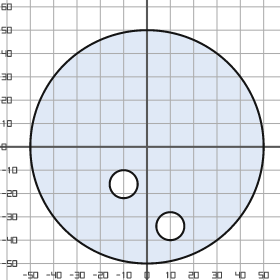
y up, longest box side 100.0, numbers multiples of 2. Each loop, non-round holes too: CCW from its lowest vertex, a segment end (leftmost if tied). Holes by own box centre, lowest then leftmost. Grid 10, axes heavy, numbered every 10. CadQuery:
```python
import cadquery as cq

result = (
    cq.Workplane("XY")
    .moveTo(0.0, 0.0)
    .circle(50.0)
    .moveTo(10.0, -34.0)
    .circle(6.0)
    .moveTo(-10.0, -16.0)
    .circle(6.0)
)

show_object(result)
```